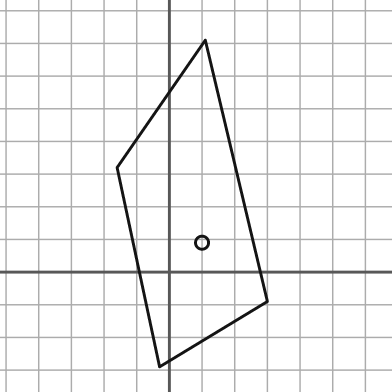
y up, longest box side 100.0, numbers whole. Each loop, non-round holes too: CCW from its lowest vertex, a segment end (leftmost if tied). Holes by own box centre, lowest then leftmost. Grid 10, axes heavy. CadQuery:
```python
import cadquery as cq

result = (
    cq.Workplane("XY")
    .moveTo(-3.0, -29.0)
    .lineTo(30.0, -9.0)
    .lineTo(11.0, 71.0)
    .lineTo(-16.0, 32.0)
    .close()
    .moveTo(10.0, 9.0)
    .circle(2.0)
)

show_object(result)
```